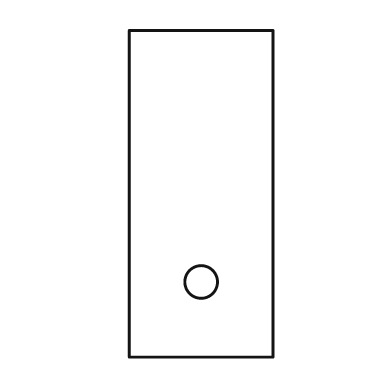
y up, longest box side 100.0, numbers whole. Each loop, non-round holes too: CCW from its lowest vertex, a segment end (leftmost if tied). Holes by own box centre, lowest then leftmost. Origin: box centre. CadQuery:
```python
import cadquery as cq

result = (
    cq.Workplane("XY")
    .moveTo(-22.0, -50.0)
    .lineTo(22.0, -50.0)
    .lineTo(22.0, 50.0)
    .lineTo(-22.0, 50.0)
    .close()
    .moveTo(0.0, -27.0)
    .circle(5.0)
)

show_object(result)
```